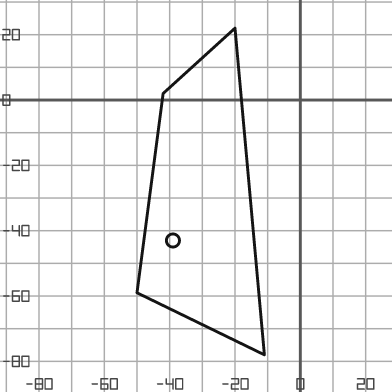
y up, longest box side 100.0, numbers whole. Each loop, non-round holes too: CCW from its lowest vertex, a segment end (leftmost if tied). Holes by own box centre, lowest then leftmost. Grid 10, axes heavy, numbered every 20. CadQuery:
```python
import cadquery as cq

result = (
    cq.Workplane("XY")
    .moveTo(-11.0, -78.0)
    .lineTo(-20.0, 22.0)
    .lineTo(-42.0, 2.0)
    .lineTo(-50.0, -59.0)
    .close()
    .moveTo(-39.0, -43.0)
    .circle(2.0)
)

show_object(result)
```